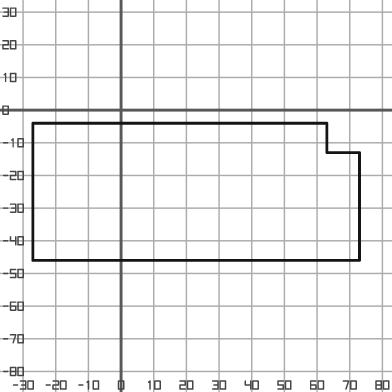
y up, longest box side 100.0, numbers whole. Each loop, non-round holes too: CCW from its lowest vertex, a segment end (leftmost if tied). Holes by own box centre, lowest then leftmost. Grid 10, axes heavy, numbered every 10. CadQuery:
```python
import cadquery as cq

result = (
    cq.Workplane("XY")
    .moveTo(-27.0, -46.0)
    .lineTo(73.0, -46.0)
    .lineTo(73.0, -13.0)
    .lineTo(63.0, -13.0)
    .lineTo(63.0, -4.0)
    .lineTo(-27.0, -4.0)
    .close()
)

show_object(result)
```